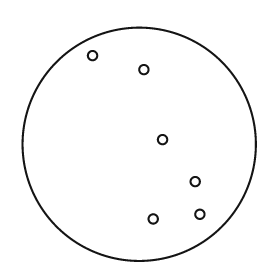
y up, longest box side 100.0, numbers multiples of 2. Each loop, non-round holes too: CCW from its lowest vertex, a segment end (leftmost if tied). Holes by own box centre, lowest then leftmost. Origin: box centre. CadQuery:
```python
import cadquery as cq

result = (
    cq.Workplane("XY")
    .moveTo(0.0, 0.0)
    .circle(50.0)
    .moveTo(6.0, -32.0)
    .circle(2.0)
    .moveTo(26.0, -30.0)
    .circle(2.0)
    .moveTo(24.0, -16.0)
    .circle(2.0)
    .moveTo(10.0, 2.0)
    .circle(2.0)
    .moveTo(2.0, 32.0)
    .circle(2.0)
    .moveTo(-20.0, 38.0)
    .circle(2.0)
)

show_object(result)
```